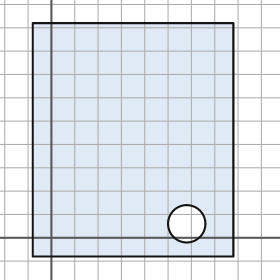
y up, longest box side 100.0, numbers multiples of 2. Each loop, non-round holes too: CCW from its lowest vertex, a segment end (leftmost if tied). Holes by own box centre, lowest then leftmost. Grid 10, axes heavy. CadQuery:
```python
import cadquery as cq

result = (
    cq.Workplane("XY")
    .moveTo(-8.0, -8.0)
    .lineTo(78.0, -8.0)
    .lineTo(78.0, 92.0)
    .lineTo(-8.0, 92.0)
    .close()
    .moveTo(58.0, 6.0)
    .circle(8.0)
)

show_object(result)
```